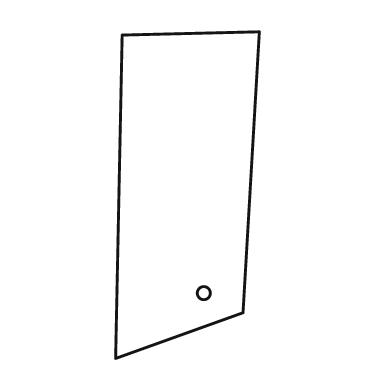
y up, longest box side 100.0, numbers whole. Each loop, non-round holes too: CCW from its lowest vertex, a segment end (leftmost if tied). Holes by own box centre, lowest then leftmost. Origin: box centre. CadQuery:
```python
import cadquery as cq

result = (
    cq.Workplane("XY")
    .moveTo(-22.0, -50.0)
    .lineTo(17.0, -36.0)
    .lineTo(22.0, 50.0)
    .lineTo(-20.0, 49.0)
    .close()
    .moveTo(5.0, -30.0)
    .circle(2.0)
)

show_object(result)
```